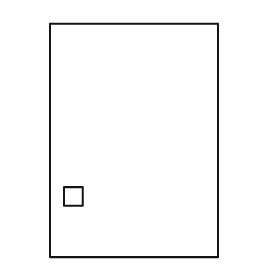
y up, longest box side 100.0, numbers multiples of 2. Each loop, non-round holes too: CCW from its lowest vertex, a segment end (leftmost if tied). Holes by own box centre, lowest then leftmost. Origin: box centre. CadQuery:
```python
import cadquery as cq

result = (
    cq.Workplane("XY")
    .moveTo(-36.0, -50.0)
    .lineTo(36.0, -50.0)
    .lineTo(36.0, 50.0)
    .lineTo(-36.0, 50.0)
    .close()
    .moveTo(-30.0, -28.0)
    .lineTo(-22.0, -28.0)
    .lineTo(-22.0, -20.0)
    .lineTo(-30.0, -20.0)
    .close()
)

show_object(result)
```